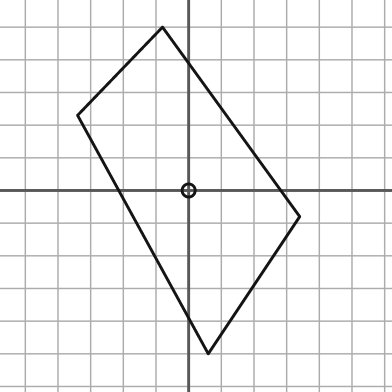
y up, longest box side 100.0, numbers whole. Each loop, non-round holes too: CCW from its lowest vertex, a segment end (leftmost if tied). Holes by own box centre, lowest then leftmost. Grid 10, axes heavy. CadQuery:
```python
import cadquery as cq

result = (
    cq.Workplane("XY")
    .moveTo(6.0, -50.0)
    .lineTo(34.0, -8.0)
    .lineTo(-8.0, 50.0)
    .lineTo(-34.0, 23.0)
    .close()
    .moveTo(0.0, 0.0)
    .circle(2.0)
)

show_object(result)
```